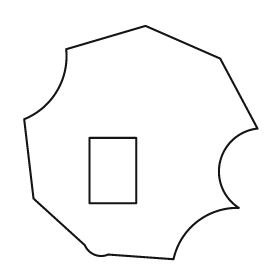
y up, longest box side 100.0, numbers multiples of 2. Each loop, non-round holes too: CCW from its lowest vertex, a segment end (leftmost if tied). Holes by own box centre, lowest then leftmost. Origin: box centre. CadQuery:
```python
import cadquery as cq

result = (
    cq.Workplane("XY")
    .moveTo(14.0, -50.0)
    .threePointArc((24.0, -34.0), (42.0, -28.0))
    .threePointArc((34.0, -8.0), (50.0, 6.0))
    .lineTo(34.0, 36.0)
    .lineTo(2.0, 50.0)
    .lineTo(-32.0, 40.0)
    .threePointArc((-36.0, 22.0), (-50.0, 10.0))
    .lineTo(-46.0, -24.0)
    .lineTo(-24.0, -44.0)
    .threePointArc((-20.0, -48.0), (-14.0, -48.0))
    .close()
    .moveTo(-22.0, -26.0)
    .lineTo(-2.0, -26.0)
    .lineTo(-2.0, 2.0)
    .lineTo(-22.0, 2.0)
    .close()
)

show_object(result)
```